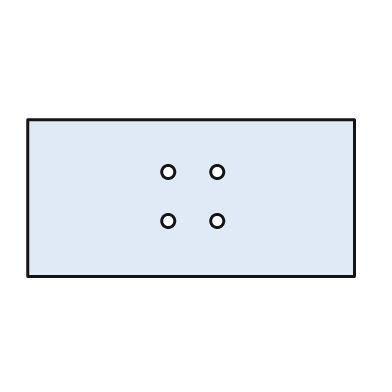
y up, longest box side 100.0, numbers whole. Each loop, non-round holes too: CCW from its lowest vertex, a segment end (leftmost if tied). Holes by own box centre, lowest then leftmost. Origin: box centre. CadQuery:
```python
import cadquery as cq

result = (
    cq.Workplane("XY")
    .moveTo(-50.0, -24.0)
    .lineTo(50.0, -24.0)
    .lineTo(50.0, 24.0)
    .lineTo(-50.0, 24.0)
    .close()
    .moveTo(-7.0, -7.0)
    .circle(2.0)
    .moveTo(8.0, -7.0)
    .circle(2.0)
    .moveTo(-7.0, 8.0)
    .circle(2.0)
    .moveTo(8.0, 8.0)
    .circle(2.0)
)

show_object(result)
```